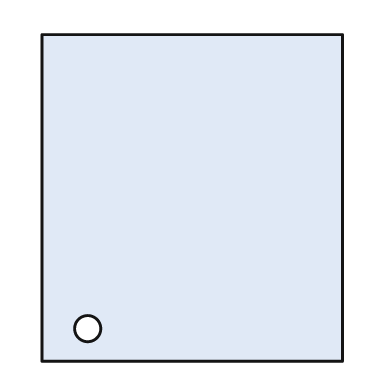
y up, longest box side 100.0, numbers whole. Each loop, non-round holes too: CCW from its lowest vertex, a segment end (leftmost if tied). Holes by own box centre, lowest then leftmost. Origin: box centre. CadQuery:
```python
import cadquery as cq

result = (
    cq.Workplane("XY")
    .moveTo(-46.0, -50.0)
    .lineTo(46.0, -50.0)
    .lineTo(46.0, 50.0)
    .lineTo(-46.0, 50.0)
    .close()
    .moveTo(-32.0, -40.0)
    .circle(4.0)
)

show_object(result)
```